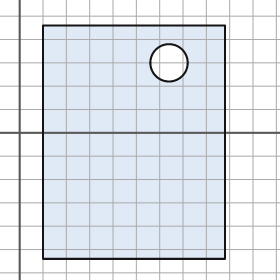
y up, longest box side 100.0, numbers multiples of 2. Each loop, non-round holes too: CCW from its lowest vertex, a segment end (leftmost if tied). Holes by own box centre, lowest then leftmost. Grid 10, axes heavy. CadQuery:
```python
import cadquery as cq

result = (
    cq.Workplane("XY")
    .moveTo(10.0, -54.0)
    .lineTo(88.0, -54.0)
    .lineTo(88.0, 46.0)
    .lineTo(10.0, 46.0)
    .close()
    .moveTo(64.0, 30.0)
    .circle(8.0)
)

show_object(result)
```